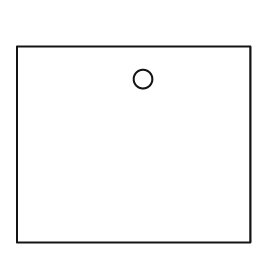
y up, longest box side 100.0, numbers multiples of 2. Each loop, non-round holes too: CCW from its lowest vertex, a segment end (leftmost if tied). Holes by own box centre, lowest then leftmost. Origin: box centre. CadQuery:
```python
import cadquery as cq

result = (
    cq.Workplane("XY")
    .moveTo(-50.0, -42.0)
    .lineTo(50.0, -42.0)
    .lineTo(50.0, 42.0)
    .lineTo(-50.0, 42.0)
    .close()
    .moveTo(4.0, 28.0)
    .circle(4.0)
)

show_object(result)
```